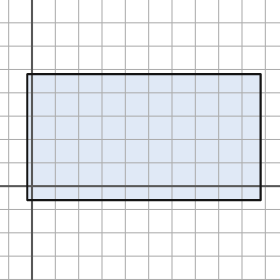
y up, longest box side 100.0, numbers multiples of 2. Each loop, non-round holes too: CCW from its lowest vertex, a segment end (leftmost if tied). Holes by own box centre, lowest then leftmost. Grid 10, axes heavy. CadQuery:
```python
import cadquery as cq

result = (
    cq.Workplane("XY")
    .moveTo(-2.0, -6.0)
    .lineTo(98.0, -6.0)
    .lineTo(98.0, 48.0)
    .lineTo(-2.0, 48.0)
    .close()
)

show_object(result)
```